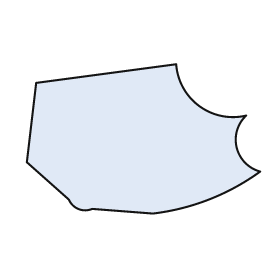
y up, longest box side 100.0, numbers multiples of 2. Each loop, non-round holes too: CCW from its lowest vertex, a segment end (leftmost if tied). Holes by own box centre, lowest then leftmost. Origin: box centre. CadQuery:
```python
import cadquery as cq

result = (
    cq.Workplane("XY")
    .moveTo(4.0, -32.0)
    .threePointArc((28.0, -26.0), (50.0, -14.0))
    .threePointArc((40.0, -4.0), (44.0, 10.0))
    .threePointArc((24.0, 14.0), (14.0, 32.0))
    .lineTo(-46.0, 24.0)
    .lineTo(-50.0, -10.0)
    .lineTo(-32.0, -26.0)
    .threePointArc((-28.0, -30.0), (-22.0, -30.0))
    .close()
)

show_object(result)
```